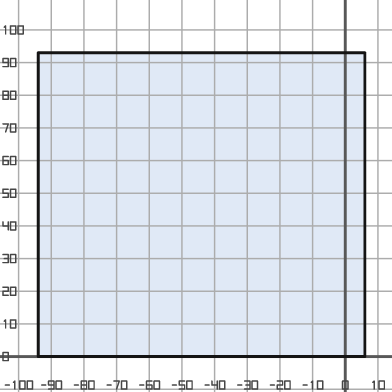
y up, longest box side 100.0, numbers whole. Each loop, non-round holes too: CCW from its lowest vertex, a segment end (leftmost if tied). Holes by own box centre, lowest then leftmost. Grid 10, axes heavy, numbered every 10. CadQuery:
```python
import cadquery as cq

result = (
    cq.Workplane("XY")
    .moveTo(-94.0, 0.0)
    .lineTo(6.0, 0.0)
    .lineTo(6.0, 93.0)
    .lineTo(-94.0, 93.0)
    .close()
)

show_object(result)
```